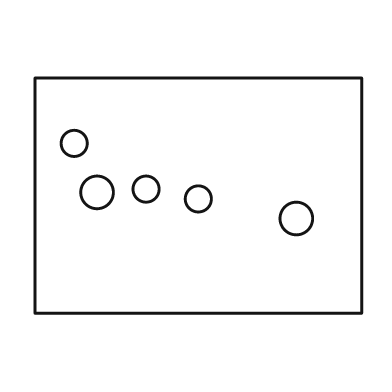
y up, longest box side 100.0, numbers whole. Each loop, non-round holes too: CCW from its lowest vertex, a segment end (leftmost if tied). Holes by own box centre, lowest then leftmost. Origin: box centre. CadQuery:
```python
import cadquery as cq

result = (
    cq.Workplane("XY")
    .moveTo(-50.0, -36.0)
    .lineTo(50.0, -36.0)
    .lineTo(50.0, 36.0)
    .lineTo(-50.0, 36.0)
    .close()
    .moveTo(30.0, -7.0)
    .circle(5.0)
    .moveTo(0.0, -1.0)
    .circle(4.0)
    .moveTo(-31.0, 1.0)
    .circle(5.0)
    .moveTo(-16.0, 2.0)
    .circle(4.0)
    .moveTo(-38.0, 16.0)
    .circle(4.0)
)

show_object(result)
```